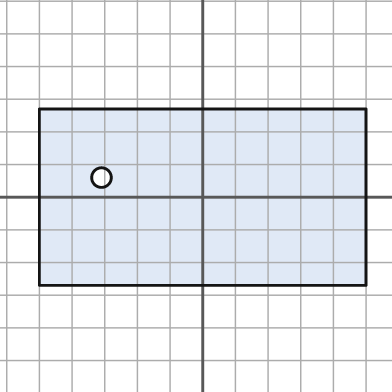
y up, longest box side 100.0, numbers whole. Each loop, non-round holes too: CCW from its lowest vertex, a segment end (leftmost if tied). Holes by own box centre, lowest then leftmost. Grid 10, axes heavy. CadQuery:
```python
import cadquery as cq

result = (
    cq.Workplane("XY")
    .moveTo(-50.0, -27.0)
    .lineTo(50.0, -27.0)
    .lineTo(50.0, 27.0)
    .lineTo(-50.0, 27.0)
    .close()
    .moveTo(-31.0, 6.0)
    .circle(3.0)
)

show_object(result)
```